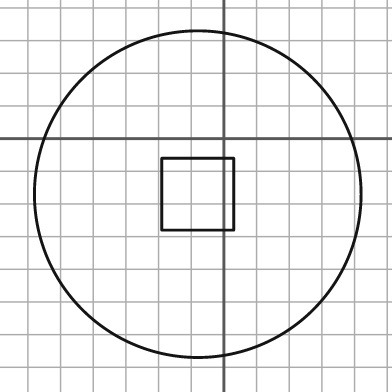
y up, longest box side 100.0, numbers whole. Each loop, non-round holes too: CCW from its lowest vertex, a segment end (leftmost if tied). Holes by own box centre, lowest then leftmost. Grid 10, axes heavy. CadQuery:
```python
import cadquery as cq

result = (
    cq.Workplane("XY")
    .moveTo(-8.0, -17.0)
    .circle(50.0)
    .moveTo(-19.0, -28.0)
    .lineTo(3.0, -28.0)
    .lineTo(3.0, -6.0)
    .lineTo(-19.0, -6.0)
    .close()
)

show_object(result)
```